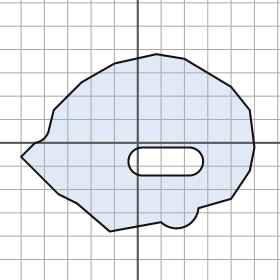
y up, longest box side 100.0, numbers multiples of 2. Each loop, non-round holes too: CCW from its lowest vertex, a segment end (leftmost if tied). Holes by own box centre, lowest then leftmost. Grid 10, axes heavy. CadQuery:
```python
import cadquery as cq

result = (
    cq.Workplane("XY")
    .moveTo(-12.0, -38.0)
    .lineTo(10.0, -34.0)
    .threePointArc((20.0, -36.0), (26.0, -28.0))
    .lineTo(40.0, -24.0)
    .lineTo(48.0, -12.0)
    .lineTo(50.0, -2.0)
    .lineTo(48.0, 14.0)
    .lineTo(40.0, 24.0)
    .lineTo(20.0, 36.0)
    .lineTo(8.0, 38.0)
    .lineTo(-10.0, 34.0)
    .lineTo(-24.0, 26.0)
    .lineTo(-36.0, 14.0)
    .lineTo(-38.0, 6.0)
    .threePointArc((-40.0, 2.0), (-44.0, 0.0))
    .lineTo(-50.0, -6.0)
    .lineTo(-34.0, -22.0)
    .lineTo(-26.0, -26.0)
    .close()
    .moveTo(2.0, -14.0)
    .lineTo(22.0, -14.0)
    .threePointArc((28.0, -8.0), (22.0, -2.0))
    .lineTo(2.0, -2.0)
    .threePointArc((-4.0, -8.0), (2.0, -14.0))
    .close()
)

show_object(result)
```